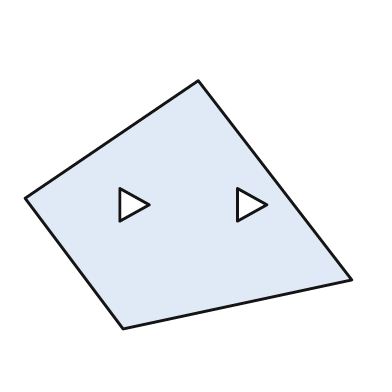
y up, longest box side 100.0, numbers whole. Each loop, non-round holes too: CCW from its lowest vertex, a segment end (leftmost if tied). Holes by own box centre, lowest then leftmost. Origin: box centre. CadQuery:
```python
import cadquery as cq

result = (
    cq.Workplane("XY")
    .moveTo(-20.0, -38.0)
    .lineTo(50.0, -23.0)
    .lineTo(3.0, 38.0)
    .lineTo(-50.0, 2.0)
    .close()
    .moveTo(-21.0, -5.0)
    .lineTo(-12.0, 0.0)
    .lineTo(-21.0, 5.0)
    .close()
    .moveTo(15.0, -5.0)
    .lineTo(24.0, 0.0)
    .lineTo(15.0, 5.0)
    .close()
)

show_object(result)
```